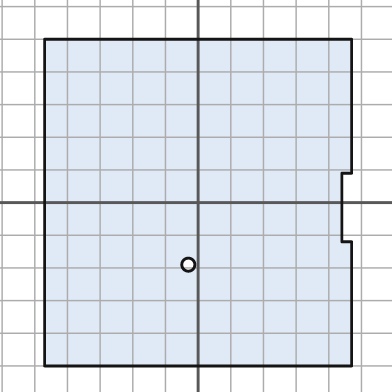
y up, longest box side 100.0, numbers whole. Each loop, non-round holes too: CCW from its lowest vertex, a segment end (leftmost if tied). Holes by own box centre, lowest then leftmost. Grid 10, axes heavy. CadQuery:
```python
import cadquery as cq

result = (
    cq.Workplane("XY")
    .moveTo(-47.0, -50.0)
    .lineTo(47.0, -50.0)
    .lineTo(47.0, -12.0)
    .lineTo(44.0, -12.0)
    .lineTo(44.0, 9.0)
    .lineTo(47.0, 9.0)
    .lineTo(47.0, 50.0)
    .lineTo(-47.0, 50.0)
    .close()
    .moveTo(-3.0, -19.0)
    .circle(2.0)
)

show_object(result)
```